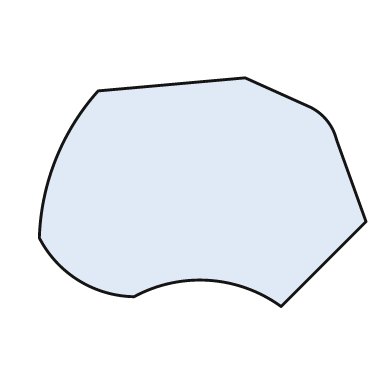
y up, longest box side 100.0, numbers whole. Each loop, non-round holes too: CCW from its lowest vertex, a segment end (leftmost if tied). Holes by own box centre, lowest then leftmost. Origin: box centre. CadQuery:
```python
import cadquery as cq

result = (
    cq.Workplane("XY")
    .moveTo(24.0, -35.0)
    .lineTo(50.0, -9.0)
    .lineTo(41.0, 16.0)
    .threePointArc((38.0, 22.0), (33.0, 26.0))
    .lineTo(13.0, 35.0)
    .lineTo(-32.0, 31.0)
    .threePointArc((-45.0, 10.0), (-50.0, -14.0))
    .threePointArc((-38.0, -27.0), (-21.0, -32.0))
    .threePointArc((2.0, -27.0), (24.0, -35.0))
    .close()
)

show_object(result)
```